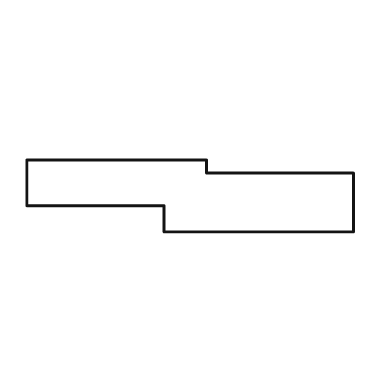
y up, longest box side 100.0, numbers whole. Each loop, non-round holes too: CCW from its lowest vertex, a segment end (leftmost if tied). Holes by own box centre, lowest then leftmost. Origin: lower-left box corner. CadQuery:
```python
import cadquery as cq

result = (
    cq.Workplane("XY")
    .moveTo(42.0, 0.0)
    .lineTo(100.0, 0.0)
    .lineTo(100.0, 18.0)
    .lineTo(55.0, 18.0)
    .lineTo(55.0, 22.0)
    .lineTo(0.0, 22.0)
    .lineTo(0.0, 8.0)
    .lineTo(42.0, 8.0)
    .close()
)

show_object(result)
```